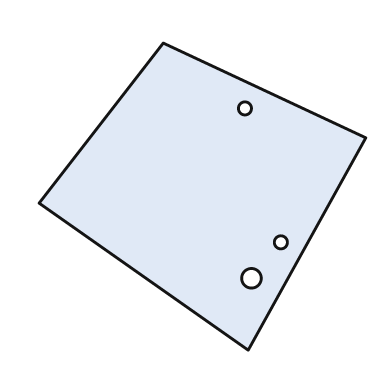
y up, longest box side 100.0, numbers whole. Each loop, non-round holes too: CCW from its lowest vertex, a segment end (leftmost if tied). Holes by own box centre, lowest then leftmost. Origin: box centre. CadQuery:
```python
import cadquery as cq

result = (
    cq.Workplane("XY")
    .moveTo(14.0, -47.0)
    .lineTo(50.0, 18.0)
    .lineTo(-12.0, 47.0)
    .lineTo(-50.0, -2.0)
    .close()
    .moveTo(15.0, -25.0)
    .circle(3.0)
    .moveTo(24.0, -14.0)
    .circle(2.0)
    .moveTo(13.0, 27.0)
    .circle(2.0)
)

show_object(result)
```